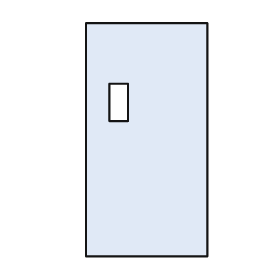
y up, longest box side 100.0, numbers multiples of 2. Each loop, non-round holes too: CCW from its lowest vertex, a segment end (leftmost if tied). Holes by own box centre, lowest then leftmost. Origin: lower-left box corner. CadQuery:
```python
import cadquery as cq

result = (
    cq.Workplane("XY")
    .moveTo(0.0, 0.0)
    .lineTo(52.0, 0.0)
    .lineTo(52.0, 100.0)
    .lineTo(0.0, 100.0)
    .close()
    .moveTo(10.0, 58.0)
    .lineTo(18.0, 58.0)
    .lineTo(18.0, 74.0)
    .lineTo(10.0, 74.0)
    .close()
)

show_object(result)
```